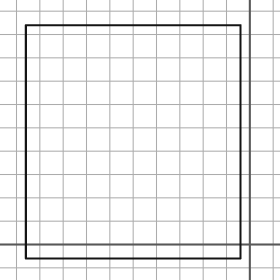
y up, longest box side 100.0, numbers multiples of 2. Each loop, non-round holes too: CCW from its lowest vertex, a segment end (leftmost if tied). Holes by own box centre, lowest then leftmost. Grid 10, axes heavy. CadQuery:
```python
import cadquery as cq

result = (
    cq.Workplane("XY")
    .moveTo(-96.0, -6.0)
    .lineTo(-4.0, -6.0)
    .lineTo(-4.0, 94.0)
    .lineTo(-96.0, 94.0)
    .close()
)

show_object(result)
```